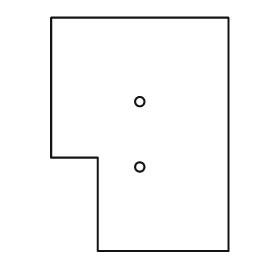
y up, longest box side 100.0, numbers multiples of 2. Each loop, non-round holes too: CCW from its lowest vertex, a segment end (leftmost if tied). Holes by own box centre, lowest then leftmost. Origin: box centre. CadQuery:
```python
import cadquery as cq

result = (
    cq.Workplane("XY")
    .moveTo(-18.0, -50.0)
    .lineTo(38.0, -50.0)
    .lineTo(38.0, 50.0)
    .lineTo(-38.0, 50.0)
    .lineTo(-38.0, -10.0)
    .lineTo(-18.0, -10.0)
    .close()
    .moveTo(0.0, -14.0)
    .circle(2.0)
    .moveTo(0.0, 14.0)
    .circle(2.0)
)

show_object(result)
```